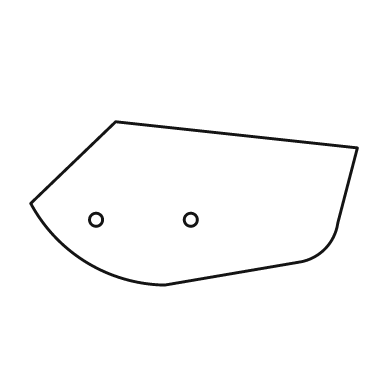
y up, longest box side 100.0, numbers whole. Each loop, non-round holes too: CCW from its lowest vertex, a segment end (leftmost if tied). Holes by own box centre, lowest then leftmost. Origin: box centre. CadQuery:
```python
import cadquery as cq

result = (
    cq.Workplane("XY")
    .moveTo(-9.0, -25.0)
    .lineTo(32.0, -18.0)
    .threePointArc((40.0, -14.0), (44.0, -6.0))
    .lineTo(50.0, 17.0)
    .lineTo(-24.0, 25.0)
    .lineTo(-50.0, 0.0)
    .threePointArc((-33.0, -18.0), (-9.0, -25.0))
    .close()
    .moveTo(-30.0, -5.0)
    .circle(2.0)
    .moveTo(-1.0, -5.0)
    .circle(2.0)
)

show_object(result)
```